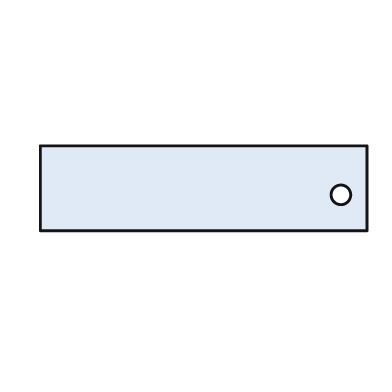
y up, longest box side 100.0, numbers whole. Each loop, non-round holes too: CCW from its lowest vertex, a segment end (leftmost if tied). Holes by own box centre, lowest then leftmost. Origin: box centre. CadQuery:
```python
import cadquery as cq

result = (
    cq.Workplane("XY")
    .moveTo(-50.0, -13.0)
    .lineTo(50.0, -13.0)
    .lineTo(50.0, 13.0)
    .lineTo(-50.0, 13.0)
    .close()
    .moveTo(42.0, -2.0)
    .circle(3.0)
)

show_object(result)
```